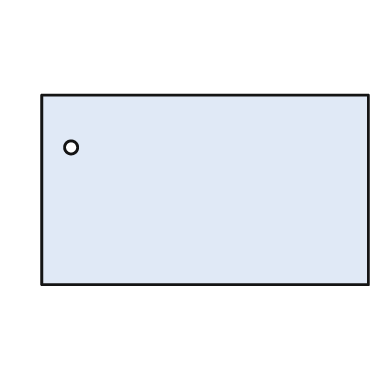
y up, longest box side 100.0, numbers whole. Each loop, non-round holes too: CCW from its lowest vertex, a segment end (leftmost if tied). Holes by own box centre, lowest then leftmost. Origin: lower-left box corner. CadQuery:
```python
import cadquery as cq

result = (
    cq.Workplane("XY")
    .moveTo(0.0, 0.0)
    .lineTo(100.0, 0.0)
    .lineTo(100.0, 58.0)
    .lineTo(0.0, 58.0)
    .close()
    .moveTo(9.0, 42.0)
    .circle(2.0)
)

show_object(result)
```